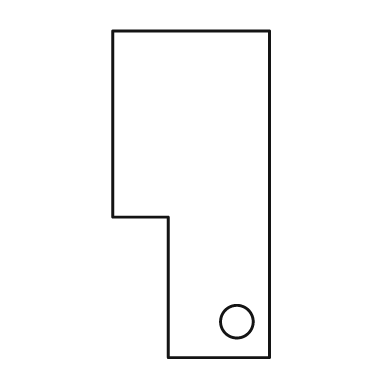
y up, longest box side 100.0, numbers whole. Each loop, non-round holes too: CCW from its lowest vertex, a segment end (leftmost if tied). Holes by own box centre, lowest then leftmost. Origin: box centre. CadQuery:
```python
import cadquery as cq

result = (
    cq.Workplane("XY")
    .moveTo(-7.0, -50.0)
    .lineTo(24.0, -50.0)
    .lineTo(24.0, 50.0)
    .lineTo(-24.0, 50.0)
    .lineTo(-24.0, -7.0)
    .lineTo(-7.0, -7.0)
    .close()
    .moveTo(14.0, -39.0)
    .circle(5.0)
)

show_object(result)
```